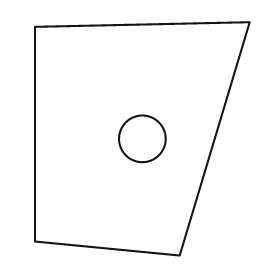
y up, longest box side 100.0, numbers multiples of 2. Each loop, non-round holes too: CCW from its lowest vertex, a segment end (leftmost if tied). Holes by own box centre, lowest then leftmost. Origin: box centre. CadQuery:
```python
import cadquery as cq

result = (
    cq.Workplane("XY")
    .moveTo(16.0, -50.0)
    .lineTo(46.0, 50.0)
    .lineTo(-46.0, 48.0)
    .lineTo(-46.0, -44.0)
    .close()
    .moveTo(0.0, 0.0)
    .circle(10.0)
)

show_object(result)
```